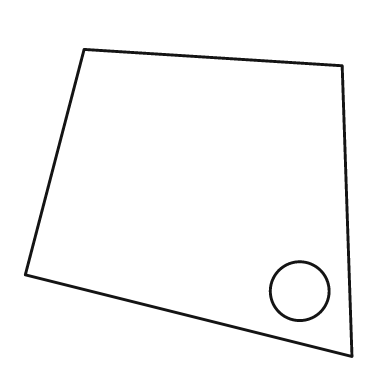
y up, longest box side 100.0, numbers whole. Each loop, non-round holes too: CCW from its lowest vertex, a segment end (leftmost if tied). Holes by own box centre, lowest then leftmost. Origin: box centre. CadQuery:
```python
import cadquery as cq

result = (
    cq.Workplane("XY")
    .moveTo(50.0, -47.0)
    .lineTo(47.0, 42.0)
    .lineTo(-32.0, 47.0)
    .lineTo(-50.0, -22.0)
    .close()
    .moveTo(34.0, -27.0)
    .circle(9.0)
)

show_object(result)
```